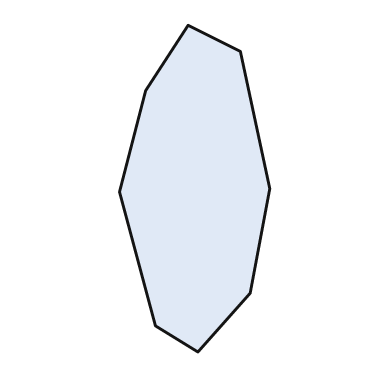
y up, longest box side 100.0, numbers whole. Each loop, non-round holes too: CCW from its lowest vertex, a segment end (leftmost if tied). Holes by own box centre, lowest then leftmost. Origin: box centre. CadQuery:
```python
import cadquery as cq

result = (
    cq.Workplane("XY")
    .moveTo(1.0, -50.0)
    .lineTo(17.0, -32.0)
    .lineTo(23.0, 0.0)
    .lineTo(14.0, 42.0)
    .lineTo(-2.0, 50.0)
    .lineTo(-15.0, 30.0)
    .lineTo(-23.0, -1.0)
    .lineTo(-12.0, -42.0)
    .close()
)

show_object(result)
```